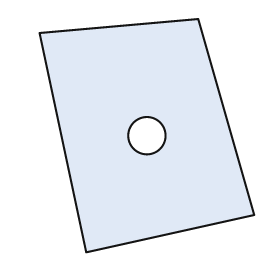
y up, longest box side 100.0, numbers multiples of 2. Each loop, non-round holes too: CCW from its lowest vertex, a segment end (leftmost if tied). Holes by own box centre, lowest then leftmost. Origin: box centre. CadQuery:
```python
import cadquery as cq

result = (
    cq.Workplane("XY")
    .moveTo(-26.0, -50.0)
    .lineTo(46.0, -34.0)
    .lineTo(22.0, 50.0)
    .lineTo(-46.0, 44.0)
    .close()
    .moveTo(0.0, 0.0)
    .circle(8.0)
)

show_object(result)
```